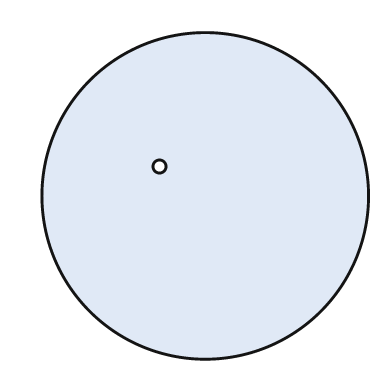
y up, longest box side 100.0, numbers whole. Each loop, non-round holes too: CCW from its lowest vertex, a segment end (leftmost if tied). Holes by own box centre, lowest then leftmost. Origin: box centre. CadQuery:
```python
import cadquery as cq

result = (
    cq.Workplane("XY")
    .moveTo(0.0, 0.0)
    .circle(50.0)
    .moveTo(-14.0, 9.0)
    .circle(2.0)
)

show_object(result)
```